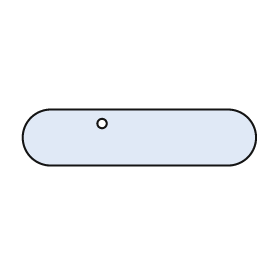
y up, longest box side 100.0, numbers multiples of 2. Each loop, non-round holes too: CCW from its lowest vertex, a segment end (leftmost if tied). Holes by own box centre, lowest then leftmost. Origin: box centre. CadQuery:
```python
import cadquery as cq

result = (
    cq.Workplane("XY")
    .moveTo(-38.0, -12.0)
    .lineTo(38.0, -12.0)
    .threePointArc((50.0, 0.0), (38.0, 12.0))
    .lineTo(-38.0, 12.0)
    .threePointArc((-50.0, 0.0), (-38.0, -12.0))
    .close()
    .moveTo(-16.0, 6.0)
    .circle(2.0)
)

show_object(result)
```